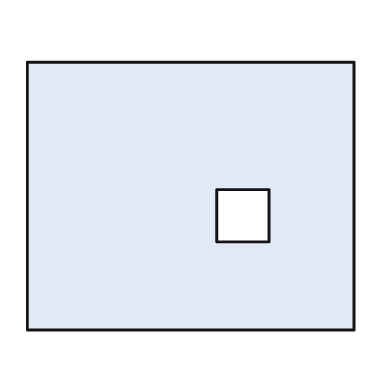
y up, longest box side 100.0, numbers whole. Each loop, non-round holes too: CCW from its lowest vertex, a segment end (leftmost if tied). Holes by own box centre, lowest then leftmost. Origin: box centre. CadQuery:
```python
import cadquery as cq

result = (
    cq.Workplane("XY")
    .moveTo(-50.0, -41.0)
    .lineTo(50.0, -41.0)
    .lineTo(50.0, 41.0)
    .lineTo(-50.0, 41.0)
    .close()
    .moveTo(8.0, -14.0)
    .lineTo(24.0, -14.0)
    .lineTo(24.0, 2.0)
    .lineTo(8.0, 2.0)
    .close()
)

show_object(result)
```